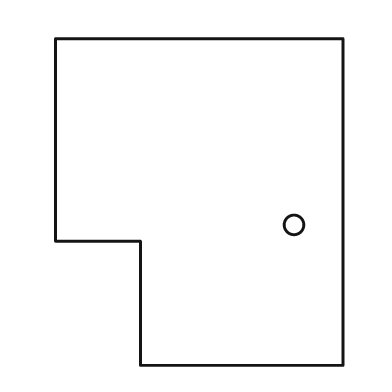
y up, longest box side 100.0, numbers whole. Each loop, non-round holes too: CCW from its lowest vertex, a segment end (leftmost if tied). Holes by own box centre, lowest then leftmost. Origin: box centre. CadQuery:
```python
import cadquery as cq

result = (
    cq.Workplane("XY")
    .moveTo(-18.0, -50.0)
    .lineTo(44.0, -50.0)
    .lineTo(44.0, 50.0)
    .lineTo(-44.0, 50.0)
    .lineTo(-44.0, -12.0)
    .lineTo(-18.0, -12.0)
    .close()
    .moveTo(29.0, -7.0)
    .circle(3.0)
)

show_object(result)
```